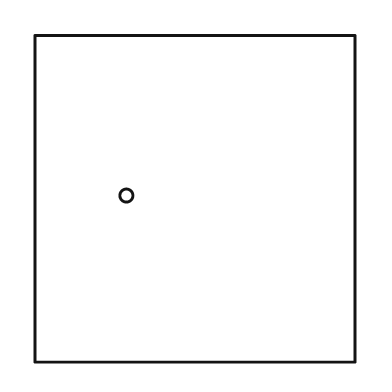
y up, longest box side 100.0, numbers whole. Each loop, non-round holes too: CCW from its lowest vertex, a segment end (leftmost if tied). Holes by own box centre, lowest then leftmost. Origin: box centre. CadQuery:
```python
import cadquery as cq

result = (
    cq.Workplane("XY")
    .moveTo(-49.0, -50.0)
    .lineTo(49.0, -50.0)
    .lineTo(49.0, 50.0)
    .lineTo(-49.0, 50.0)
    .close()
    .moveTo(-21.0, 1.0)
    .circle(2.0)
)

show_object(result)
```